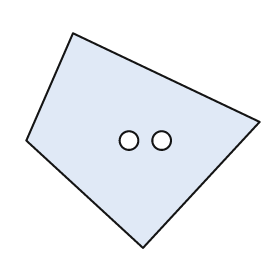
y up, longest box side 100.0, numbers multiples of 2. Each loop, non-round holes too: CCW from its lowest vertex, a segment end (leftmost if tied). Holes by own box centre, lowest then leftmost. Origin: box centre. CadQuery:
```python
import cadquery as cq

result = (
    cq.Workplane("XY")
    .moveTo(0.0, -46.0)
    .lineTo(50.0, 8.0)
    .lineTo(-30.0, 46.0)
    .lineTo(-50.0, 0.0)
    .close()
    .moveTo(-6.0, 0.0)
    .circle(4.0)
    .moveTo(8.0, 0.0)
    .circle(4.0)
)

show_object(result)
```